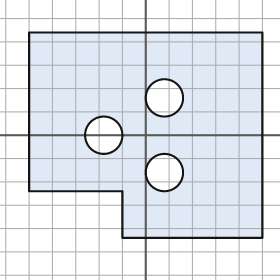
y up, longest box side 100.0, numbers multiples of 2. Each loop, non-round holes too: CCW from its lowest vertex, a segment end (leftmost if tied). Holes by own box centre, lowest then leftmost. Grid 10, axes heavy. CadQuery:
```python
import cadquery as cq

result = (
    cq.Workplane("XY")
    .moveTo(-10.0, -44.0)
    .lineTo(50.0, -44.0)
    .lineTo(50.0, 44.0)
    .lineTo(-50.0, 44.0)
    .lineTo(-50.0, -24.0)
    .lineTo(-10.0, -24.0)
    .close()
    .moveTo(8.0, -16.0)
    .circle(8.0)
    .moveTo(-18.0, 0.0)
    .circle(8.0)
    .moveTo(8.0, 16.0)
    .circle(8.0)
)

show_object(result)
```